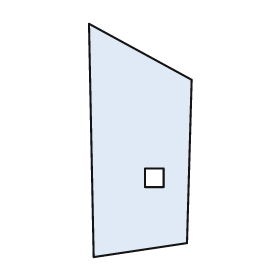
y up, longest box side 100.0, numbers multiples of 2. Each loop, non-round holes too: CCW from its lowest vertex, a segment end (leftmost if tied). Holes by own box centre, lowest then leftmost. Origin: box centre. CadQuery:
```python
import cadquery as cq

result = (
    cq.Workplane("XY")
    .moveTo(-20.0, -50.0)
    .lineTo(20.0, -44.0)
    .lineTo(22.0, 26.0)
    .lineTo(-22.0, 50.0)
    .close()
    .moveTo(2.0, -20.0)
    .lineTo(10.0, -20.0)
    .lineTo(10.0, -12.0)
    .lineTo(2.0, -12.0)
    .close()
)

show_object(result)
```